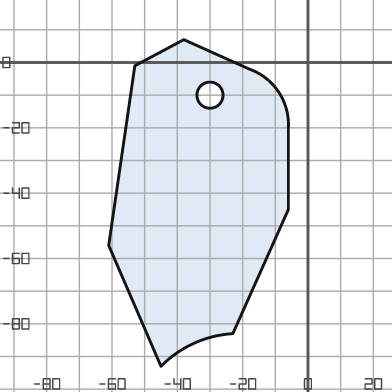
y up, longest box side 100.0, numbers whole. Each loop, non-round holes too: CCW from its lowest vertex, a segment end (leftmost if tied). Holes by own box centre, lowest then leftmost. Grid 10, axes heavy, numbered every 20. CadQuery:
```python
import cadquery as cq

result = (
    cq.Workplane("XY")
    .moveTo(-45.0, -93.0)
    .threePointArc((-35.0, -86.0), (-23.0, -83.0))
    .lineTo(-6.0, -45.0)
    .lineTo(-6.0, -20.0)
    .threePointArc((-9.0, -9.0), (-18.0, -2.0))
    .lineTo(-38.0, 7.0)
    .lineTo(-53.0, -1.0)
    .lineTo(-61.0, -56.0)
    .close()
    .moveTo(-30.0, -10.0)
    .circle(4.0)
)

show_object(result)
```